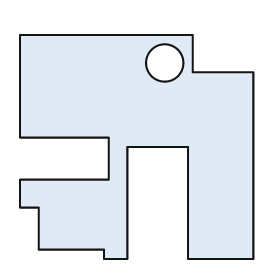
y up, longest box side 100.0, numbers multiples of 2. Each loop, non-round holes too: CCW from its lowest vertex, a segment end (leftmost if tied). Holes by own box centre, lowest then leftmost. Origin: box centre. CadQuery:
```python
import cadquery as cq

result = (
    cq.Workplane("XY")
    .moveTo(-14.0, -48.0)
    .lineTo(-4.0, -48.0)
    .lineTo(-4.0, 0.0)
    .lineTo(22.0, 0.0)
    .lineTo(22.0, -48.0)
    .lineTo(50.0, -48.0)
    .lineTo(50.0, 32.0)
    .lineTo(24.0, 32.0)
    .lineTo(24.0, 48.0)
    .lineTo(-50.0, 48.0)
    .lineTo(-50.0, 4.0)
    .lineTo(-12.0, 4.0)
    .lineTo(-12.0, -14.0)
    .lineTo(-50.0, -14.0)
    .lineTo(-50.0, -26.0)
    .lineTo(-42.0, -26.0)
    .lineTo(-42.0, -44.0)
    .lineTo(-14.0, -44.0)
    .close()
    .moveTo(12.0, 36.0)
    .circle(8.0)
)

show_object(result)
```